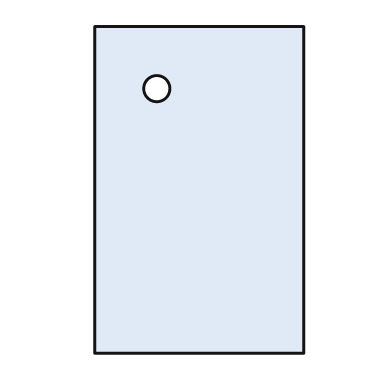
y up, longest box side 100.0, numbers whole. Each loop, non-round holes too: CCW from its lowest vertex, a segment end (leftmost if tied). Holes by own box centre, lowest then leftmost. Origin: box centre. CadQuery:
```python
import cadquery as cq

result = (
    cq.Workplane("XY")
    .moveTo(-32.0, -50.0)
    .lineTo(32.0, -50.0)
    .lineTo(32.0, 50.0)
    .lineTo(-32.0, 50.0)
    .close()
    .moveTo(-13.0, 31.0)
    .circle(4.0)
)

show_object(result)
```